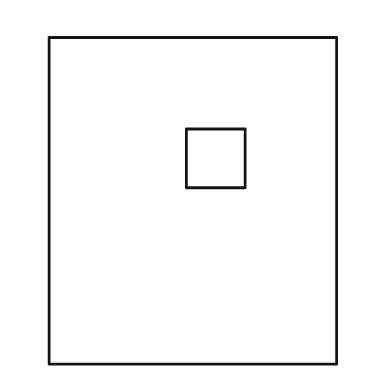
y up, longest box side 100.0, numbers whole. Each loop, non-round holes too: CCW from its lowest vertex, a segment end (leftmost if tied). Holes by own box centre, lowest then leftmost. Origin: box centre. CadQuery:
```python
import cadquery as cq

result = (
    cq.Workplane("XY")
    .moveTo(-44.0, -50.0)
    .lineTo(44.0, -50.0)
    .lineTo(44.0, 50.0)
    .lineTo(-44.0, 50.0)
    .close()
    .moveTo(-2.0, 4.0)
    .lineTo(16.0, 4.0)
    .lineTo(16.0, 22.0)
    .lineTo(-2.0, 22.0)
    .close()
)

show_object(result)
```